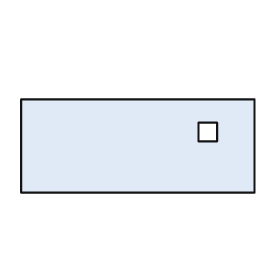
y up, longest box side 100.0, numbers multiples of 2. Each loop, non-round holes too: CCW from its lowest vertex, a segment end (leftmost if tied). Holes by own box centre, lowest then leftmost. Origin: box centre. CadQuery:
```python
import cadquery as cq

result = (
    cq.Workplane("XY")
    .moveTo(-50.0, -20.0)
    .lineTo(50.0, -20.0)
    .lineTo(50.0, 20.0)
    .lineTo(-50.0, 20.0)
    .close()
    .moveTo(26.0, 2.0)
    .lineTo(34.0, 2.0)
    .lineTo(34.0, 10.0)
    .lineTo(26.0, 10.0)
    .close()
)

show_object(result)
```